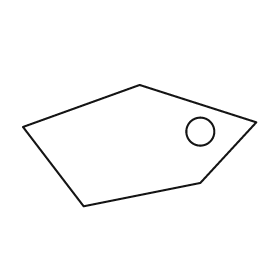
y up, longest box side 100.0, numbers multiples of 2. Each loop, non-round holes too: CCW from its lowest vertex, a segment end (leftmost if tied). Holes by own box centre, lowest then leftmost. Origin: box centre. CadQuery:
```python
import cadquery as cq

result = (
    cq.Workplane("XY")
    .moveTo(-24.0, -26.0)
    .lineTo(26.0, -16.0)
    .lineTo(50.0, 10.0)
    .lineTo(0.0, 26.0)
    .lineTo(-50.0, 8.0)
    .close()
    .moveTo(26.0, 6.0)
    .circle(6.0)
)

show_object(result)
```